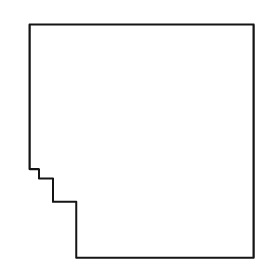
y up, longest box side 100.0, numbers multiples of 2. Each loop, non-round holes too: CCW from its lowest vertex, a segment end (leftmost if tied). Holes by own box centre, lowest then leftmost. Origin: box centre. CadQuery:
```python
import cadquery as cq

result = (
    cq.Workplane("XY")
    .moveTo(-28.0, -50.0)
    .lineTo(48.0, -50.0)
    .lineTo(48.0, 50.0)
    .lineTo(-48.0, 50.0)
    .lineTo(-48.0, -12.0)
    .lineTo(-44.0, -12.0)
    .lineTo(-44.0, -16.0)
    .lineTo(-38.0, -16.0)
    .lineTo(-38.0, -26.0)
    .lineTo(-28.0, -26.0)
    .close()
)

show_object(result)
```